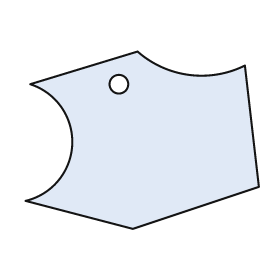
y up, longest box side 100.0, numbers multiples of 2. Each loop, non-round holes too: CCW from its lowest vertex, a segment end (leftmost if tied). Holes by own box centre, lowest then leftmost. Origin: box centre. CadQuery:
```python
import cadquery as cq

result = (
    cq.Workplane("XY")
    .moveTo(-4.0, -38.0)
    .lineTo(50.0, -20.0)
    .lineTo(44.0, 32.0)
    .threePointArc((20.0, 28.0), (-2.0, 38.0))
    .lineTo(-48.0, 24.0)
    .threePointArc((-30.0, -2.0), (-50.0, -26.0))
    .close()
    .moveTo(-10.0, 24.0)
    .circle(4.0)
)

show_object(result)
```